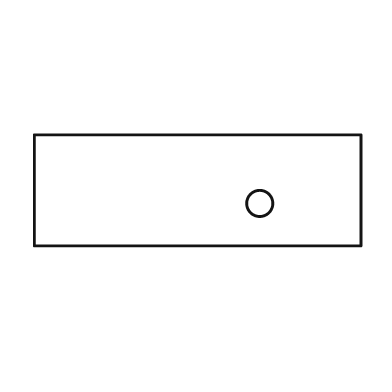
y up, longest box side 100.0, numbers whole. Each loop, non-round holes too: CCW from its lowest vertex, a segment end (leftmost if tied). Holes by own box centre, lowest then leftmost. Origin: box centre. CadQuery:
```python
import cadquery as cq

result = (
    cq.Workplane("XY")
    .moveTo(-50.0, -17.0)
    .lineTo(50.0, -17.0)
    .lineTo(50.0, 17.0)
    .lineTo(-50.0, 17.0)
    .close()
    .moveTo(19.0, -4.0)
    .circle(4.0)
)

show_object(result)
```